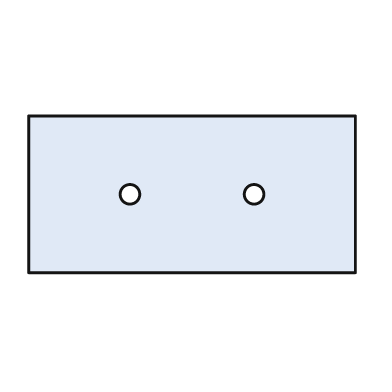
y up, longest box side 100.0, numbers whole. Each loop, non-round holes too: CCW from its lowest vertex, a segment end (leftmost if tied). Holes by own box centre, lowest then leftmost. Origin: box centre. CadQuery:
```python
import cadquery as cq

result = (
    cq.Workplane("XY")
    .moveTo(-50.0, -24.0)
    .lineTo(50.0, -24.0)
    .lineTo(50.0, 24.0)
    .lineTo(-50.0, 24.0)
    .close()
    .moveTo(-19.0, 0.0)
    .circle(3.0)
    .moveTo(19.0, 0.0)
    .circle(3.0)
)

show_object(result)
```